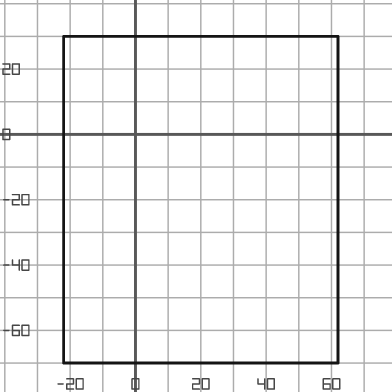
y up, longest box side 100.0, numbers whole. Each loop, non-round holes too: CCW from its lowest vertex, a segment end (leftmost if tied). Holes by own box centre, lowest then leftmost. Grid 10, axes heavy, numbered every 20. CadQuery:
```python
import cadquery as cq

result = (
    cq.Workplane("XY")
    .moveTo(-22.0, -70.0)
    .lineTo(62.0, -70.0)
    .lineTo(62.0, 30.0)
    .lineTo(-22.0, 30.0)
    .close()
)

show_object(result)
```